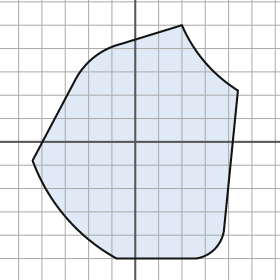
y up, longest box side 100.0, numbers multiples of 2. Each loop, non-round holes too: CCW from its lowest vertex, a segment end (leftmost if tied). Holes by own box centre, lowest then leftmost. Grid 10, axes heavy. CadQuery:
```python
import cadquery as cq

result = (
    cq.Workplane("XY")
    .moveTo(-8.0, -50.0)
    .lineTo(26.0, -50.0)
    .threePointArc((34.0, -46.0), (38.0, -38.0))
    .lineTo(44.0, 22.0)
    .threePointArc((30.0, 34.0), (20.0, 50.0))
    .lineTo(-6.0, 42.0)
    .threePointArc((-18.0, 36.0), (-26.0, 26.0))
    .lineTo(-44.0, -8.0)
    .threePointArc((-30.0, -32.0), (-8.0, -50.0))
    .close()
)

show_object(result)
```